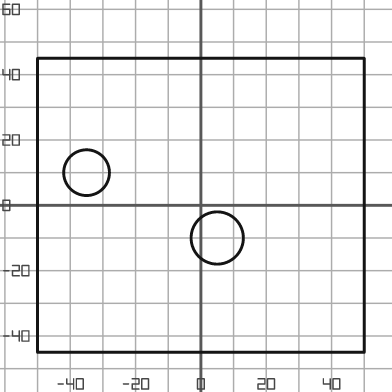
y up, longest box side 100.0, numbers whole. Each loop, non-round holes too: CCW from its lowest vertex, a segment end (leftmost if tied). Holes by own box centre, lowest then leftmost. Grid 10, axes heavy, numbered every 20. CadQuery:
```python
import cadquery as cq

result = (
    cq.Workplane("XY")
    .moveTo(-50.0, -45.0)
    .lineTo(50.0, -45.0)
    .lineTo(50.0, 45.0)
    .lineTo(-50.0, 45.0)
    .close()
    .moveTo(5.0, -10.0)
    .circle(8.0)
    .moveTo(-35.0, 10.0)
    .circle(7.0)
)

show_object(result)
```